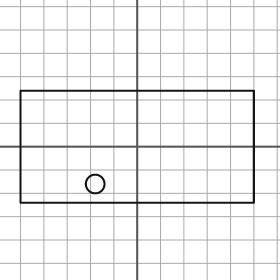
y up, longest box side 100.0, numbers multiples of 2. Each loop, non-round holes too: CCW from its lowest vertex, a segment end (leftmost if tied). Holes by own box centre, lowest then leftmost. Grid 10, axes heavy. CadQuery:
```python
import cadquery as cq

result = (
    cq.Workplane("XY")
    .moveTo(-50.0, -24.0)
    .lineTo(50.0, -24.0)
    .lineTo(50.0, 24.0)
    .lineTo(-50.0, 24.0)
    .close()
    .moveTo(-18.0, -16.0)
    .circle(4.0)
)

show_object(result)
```